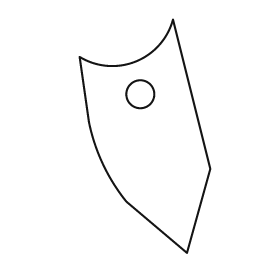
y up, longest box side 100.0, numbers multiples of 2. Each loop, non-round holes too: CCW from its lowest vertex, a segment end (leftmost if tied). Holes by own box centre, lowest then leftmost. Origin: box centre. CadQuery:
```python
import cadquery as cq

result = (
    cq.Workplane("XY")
    .moveTo(18.0, -50.0)
    .lineTo(28.0, -14.0)
    .lineTo(12.0, 50.0)
    .threePointArc((-4.0, 32.0), (-28.0, 34.0))
    .lineTo(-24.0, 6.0)
    .threePointArc((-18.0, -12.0), (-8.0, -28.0))
    .close()
    .moveTo(-2.0, 18.0)
    .circle(6.0)
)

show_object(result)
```